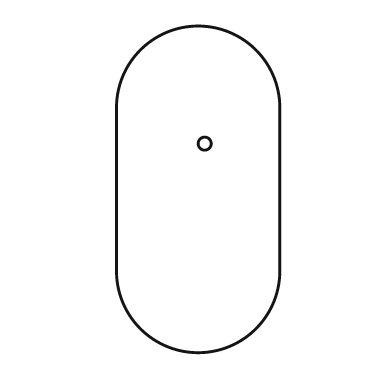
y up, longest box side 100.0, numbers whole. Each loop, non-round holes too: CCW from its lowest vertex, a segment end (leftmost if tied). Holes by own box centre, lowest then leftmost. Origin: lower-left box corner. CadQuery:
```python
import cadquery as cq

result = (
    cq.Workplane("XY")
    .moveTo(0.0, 25.0)
    .threePointArc((25.0, 0.0), (50.0, 25.0))
    .lineTo(50.0, 75.0)
    .threePointArc((25.0, 100.0), (0.0, 75.0))
    .close()
    .moveTo(27.0, 64.0)
    .circle(2.0)
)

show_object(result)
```